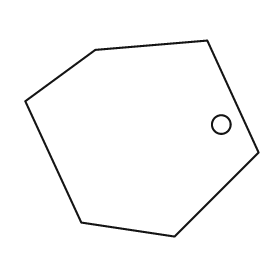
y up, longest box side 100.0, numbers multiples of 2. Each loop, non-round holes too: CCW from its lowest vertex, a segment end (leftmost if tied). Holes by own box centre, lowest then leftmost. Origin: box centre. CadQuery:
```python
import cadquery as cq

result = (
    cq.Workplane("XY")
    .moveTo(14.0, -42.0)
    .lineTo(50.0, -6.0)
    .lineTo(28.0, 42.0)
    .lineTo(-20.0, 38.0)
    .lineTo(-50.0, 16.0)
    .lineTo(-26.0, -36.0)
    .close()
    .moveTo(34.0, 6.0)
    .circle(4.0)
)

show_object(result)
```